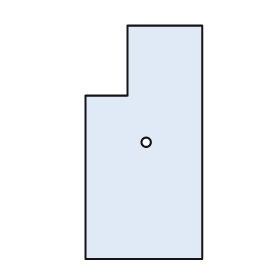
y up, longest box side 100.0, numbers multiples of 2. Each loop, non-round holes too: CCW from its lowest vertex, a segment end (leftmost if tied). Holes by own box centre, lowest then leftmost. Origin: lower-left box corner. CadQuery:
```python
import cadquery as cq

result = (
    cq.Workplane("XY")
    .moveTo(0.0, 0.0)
    .lineTo(50.0, 0.0)
    .lineTo(50.0, 100.0)
    .lineTo(18.0, 100.0)
    .lineTo(18.0, 70.0)
    .lineTo(0.0, 70.0)
    .close()
    .moveTo(26.0, 50.0)
    .circle(2.0)
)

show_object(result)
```